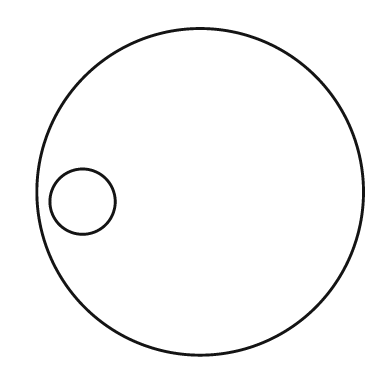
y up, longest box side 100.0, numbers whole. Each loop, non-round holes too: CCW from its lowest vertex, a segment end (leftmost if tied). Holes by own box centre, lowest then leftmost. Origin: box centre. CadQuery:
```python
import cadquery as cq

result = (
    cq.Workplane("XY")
    .moveTo(0.0, 0.0)
    .circle(50.0)
    .moveTo(-36.0, -3.0)
    .circle(10.0)
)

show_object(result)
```